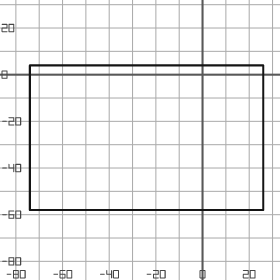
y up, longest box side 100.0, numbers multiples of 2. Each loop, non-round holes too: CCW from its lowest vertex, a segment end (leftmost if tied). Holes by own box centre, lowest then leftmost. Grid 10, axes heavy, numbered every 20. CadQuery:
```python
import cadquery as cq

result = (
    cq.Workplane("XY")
    .moveTo(-74.0, -58.0)
    .lineTo(26.0, -58.0)
    .lineTo(26.0, 4.0)
    .lineTo(-74.0, 4.0)
    .close()
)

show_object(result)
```